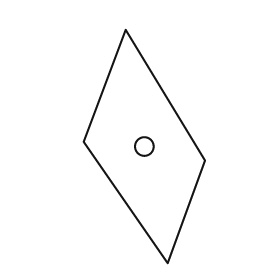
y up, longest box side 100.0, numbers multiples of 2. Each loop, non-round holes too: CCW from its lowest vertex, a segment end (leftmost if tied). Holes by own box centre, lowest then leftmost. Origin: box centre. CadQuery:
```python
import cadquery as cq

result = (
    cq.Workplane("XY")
    .moveTo(10.0, -50.0)
    .lineTo(26.0, -6.0)
    .lineTo(-8.0, 50.0)
    .lineTo(-26.0, 2.0)
    .close()
    .moveTo(0.0, 0.0)
    .circle(4.0)
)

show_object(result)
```